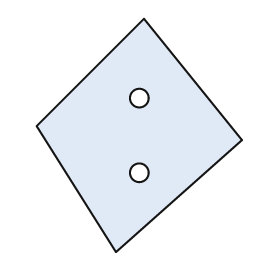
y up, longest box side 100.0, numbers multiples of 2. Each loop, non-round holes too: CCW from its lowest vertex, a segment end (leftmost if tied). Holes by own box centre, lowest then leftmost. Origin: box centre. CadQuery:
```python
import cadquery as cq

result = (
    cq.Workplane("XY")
    .moveTo(-10.0, -50.0)
    .lineTo(44.0, -2.0)
    .lineTo(2.0, 50.0)
    .lineTo(-44.0, 4.0)
    .close()
    .moveTo(0.0, -16.0)
    .circle(4.0)
    .moveTo(0.0, 16.0)
    .circle(4.0)
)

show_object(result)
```